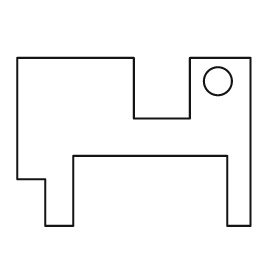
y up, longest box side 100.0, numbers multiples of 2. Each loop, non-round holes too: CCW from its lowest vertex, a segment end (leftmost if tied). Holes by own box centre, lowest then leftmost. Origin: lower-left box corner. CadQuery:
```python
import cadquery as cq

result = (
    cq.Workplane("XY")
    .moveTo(12.0, 0.0)
    .lineTo(24.0, 0.0)
    .lineTo(24.0, 30.0)
    .lineTo(90.0, 30.0)
    .lineTo(90.0, 0.0)
    .lineTo(100.0, 0.0)
    .lineTo(100.0, 72.0)
    .lineTo(74.0, 72.0)
    .lineTo(74.0, 46.0)
    .lineTo(50.0, 46.0)
    .lineTo(50.0, 72.0)
    .lineTo(0.0, 72.0)
    .lineTo(0.0, 20.0)
    .lineTo(12.0, 20.0)
    .close()
    .moveTo(86.0, 62.0)
    .circle(6.0)
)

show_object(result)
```